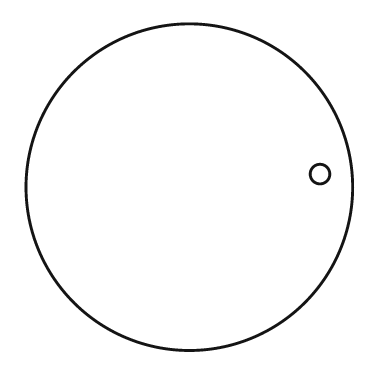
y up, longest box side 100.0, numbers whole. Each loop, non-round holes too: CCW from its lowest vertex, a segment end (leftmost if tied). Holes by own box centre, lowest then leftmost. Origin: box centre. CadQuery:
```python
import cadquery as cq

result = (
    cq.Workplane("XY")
    .moveTo(0.0, 0.0)
    .circle(50.0)
    .moveTo(40.0, 4.0)
    .circle(3.0)
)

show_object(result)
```